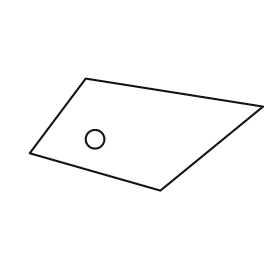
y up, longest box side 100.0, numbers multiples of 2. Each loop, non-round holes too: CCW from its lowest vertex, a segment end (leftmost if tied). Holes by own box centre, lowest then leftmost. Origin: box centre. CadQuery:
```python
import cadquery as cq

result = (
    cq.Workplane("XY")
    .moveTo(6.0, -24.0)
    .lineTo(50.0, 12.0)
    .lineTo(-26.0, 24.0)
    .lineTo(-50.0, -8.0)
    .close()
    .moveTo(-22.0, -2.0)
    .circle(4.0)
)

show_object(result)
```